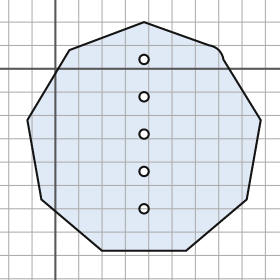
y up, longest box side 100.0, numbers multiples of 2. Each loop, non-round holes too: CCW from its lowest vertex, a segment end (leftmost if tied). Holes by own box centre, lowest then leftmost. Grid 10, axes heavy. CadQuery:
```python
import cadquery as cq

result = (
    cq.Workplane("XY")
    .moveTo(20.0, -78.0)
    .lineTo(56.0, -78.0)
    .lineTo(82.0, -56.0)
    .lineTo(88.0, -22.0)
    .lineTo(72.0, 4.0)
    .threePointArc((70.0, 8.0), (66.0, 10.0))
    .lineTo(38.0, 20.0)
    .lineTo(6.0, 8.0)
    .lineTo(-12.0, -22.0)
    .lineTo(-6.0, -56.0)
    .close()
    .moveTo(38.0, -60.0)
    .circle(2.0)
    .moveTo(38.0, -44.0)
    .circle(2.0)
    .moveTo(38.0, -28.0)
    .circle(2.0)
    .moveTo(38.0, -12.0)
    .circle(2.0)
    .moveTo(38.0, 4.0)
    .circle(2.0)
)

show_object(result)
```